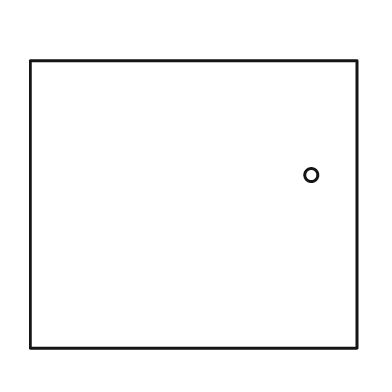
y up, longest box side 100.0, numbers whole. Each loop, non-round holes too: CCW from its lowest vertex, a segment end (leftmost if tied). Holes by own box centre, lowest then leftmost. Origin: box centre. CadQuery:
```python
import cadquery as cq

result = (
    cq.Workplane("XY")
    .moveTo(-50.0, -44.0)
    .lineTo(50.0, -44.0)
    .lineTo(50.0, 44.0)
    .lineTo(-50.0, 44.0)
    .close()
    .moveTo(36.0, 9.0)
    .circle(2.0)
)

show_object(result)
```